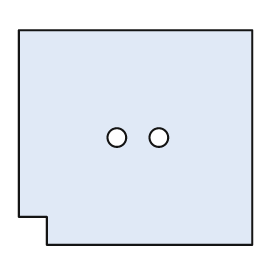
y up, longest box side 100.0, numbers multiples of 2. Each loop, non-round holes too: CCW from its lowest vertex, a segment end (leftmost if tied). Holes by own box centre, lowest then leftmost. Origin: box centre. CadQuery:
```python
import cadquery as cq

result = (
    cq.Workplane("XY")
    .moveTo(-38.0, -46.0)
    .lineTo(50.0, -46.0)
    .lineTo(50.0, 46.0)
    .lineTo(-50.0, 46.0)
    .lineTo(-50.0, -34.0)
    .lineTo(-38.0, -34.0)
    .close()
    .moveTo(-8.0, 0.0)
    .circle(4.0)
    .moveTo(10.0, 0.0)
    .circle(4.0)
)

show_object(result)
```